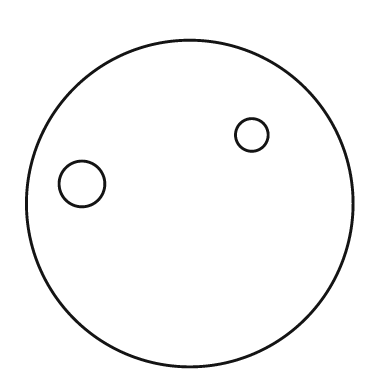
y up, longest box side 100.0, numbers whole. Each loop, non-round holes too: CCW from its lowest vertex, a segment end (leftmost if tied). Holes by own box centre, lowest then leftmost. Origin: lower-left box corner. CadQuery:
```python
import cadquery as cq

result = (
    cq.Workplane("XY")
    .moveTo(50.0, 50.0)
    .circle(50.0)
    .moveTo(17.0, 56.0)
    .circle(7.0)
    .moveTo(69.0, 71.0)
    .circle(5.0)
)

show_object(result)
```